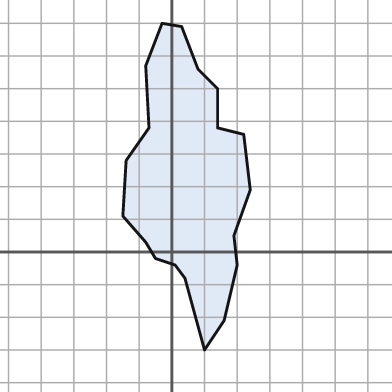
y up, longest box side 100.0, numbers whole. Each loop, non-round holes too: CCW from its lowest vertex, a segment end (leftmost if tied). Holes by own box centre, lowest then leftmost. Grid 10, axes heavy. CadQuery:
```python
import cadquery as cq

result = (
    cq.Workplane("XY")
    .moveTo(10.0, -30.0)
    .lineTo(16.0, -21.0)
    .lineTo(20.0, -4.0)
    .lineTo(19.0, 5.0)
    .lineTo(24.0, 19.0)
    .lineTo(22.0, 36.0)
    .lineTo(14.0, 38.0)
    .lineTo(14.0, 50.0)
    .lineTo(8.0, 56.0)
    .lineTo(3.0, 69.0)
    .lineTo(-3.0, 70.0)
    .lineTo(-8.0, 57.0)
    .lineTo(-7.0, 38.0)
    .lineTo(-14.0, 28.0)
    .lineTo(-15.0, 11.0)
    .lineTo(-8.0, 3.0)
    .lineTo(-5.0, -2.0)
    .lineTo(1.0, -4.0)
    .lineTo(4.0, -8.0)
    .close()
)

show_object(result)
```